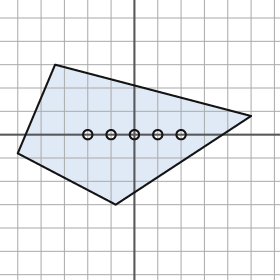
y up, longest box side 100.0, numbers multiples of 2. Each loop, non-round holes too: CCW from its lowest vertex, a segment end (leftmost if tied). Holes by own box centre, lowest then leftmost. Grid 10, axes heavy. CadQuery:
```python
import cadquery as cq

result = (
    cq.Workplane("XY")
    .moveTo(-8.0, -30.0)
    .lineTo(50.0, 8.0)
    .lineTo(-34.0, 30.0)
    .lineTo(-50.0, -8.0)
    .close()
    .moveTo(-20.0, 0.0)
    .circle(2.0)
    .moveTo(-10.0, 0.0)
    .circle(2.0)
    .moveTo(0.0, 0.0)
    .circle(2.0)
    .moveTo(10.0, 0.0)
    .circle(2.0)
    .moveTo(20.0, 0.0)
    .circle(2.0)
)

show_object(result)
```